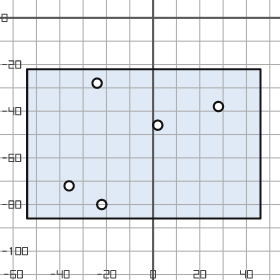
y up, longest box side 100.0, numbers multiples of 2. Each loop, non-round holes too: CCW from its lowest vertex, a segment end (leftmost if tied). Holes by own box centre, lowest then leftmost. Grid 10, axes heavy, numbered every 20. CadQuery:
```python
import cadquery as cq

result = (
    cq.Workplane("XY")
    .moveTo(-54.0, -86.0)
    .lineTo(46.0, -86.0)
    .lineTo(46.0, -22.0)
    .lineTo(-54.0, -22.0)
    .close()
    .moveTo(-22.0, -80.0)
    .circle(2.0)
    .moveTo(-36.0, -72.0)
    .circle(2.0)
    .moveTo(2.0, -46.0)
    .circle(2.0)
    .moveTo(28.0, -38.0)
    .circle(2.0)
    .moveTo(-24.0, -28.0)
    .circle(2.0)
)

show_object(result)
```